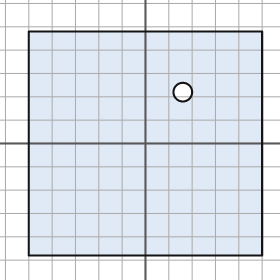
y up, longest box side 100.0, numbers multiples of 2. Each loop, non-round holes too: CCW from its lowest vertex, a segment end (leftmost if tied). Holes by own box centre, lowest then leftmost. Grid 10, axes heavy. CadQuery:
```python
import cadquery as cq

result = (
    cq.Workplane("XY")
    .moveTo(-50.0, -48.0)
    .lineTo(50.0, -48.0)
    .lineTo(50.0, 48.0)
    .lineTo(-50.0, 48.0)
    .close()
    .moveTo(16.0, 22.0)
    .circle(4.0)
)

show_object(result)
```